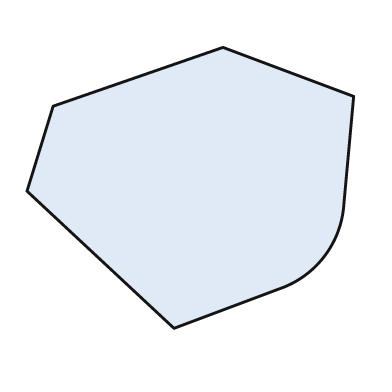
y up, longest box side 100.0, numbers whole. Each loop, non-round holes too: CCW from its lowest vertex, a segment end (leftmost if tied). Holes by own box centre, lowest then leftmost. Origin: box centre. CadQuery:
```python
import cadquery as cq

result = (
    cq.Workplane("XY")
    .moveTo(-5.0, -43.0)
    .lineTo(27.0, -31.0)
    .threePointArc((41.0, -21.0), (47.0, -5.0))
    .lineTo(50.0, 28.0)
    .lineTo(10.0, 43.0)
    .lineTo(-42.0, 25.0)
    .lineTo(-50.0, -1.0)
    .close()
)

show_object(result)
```